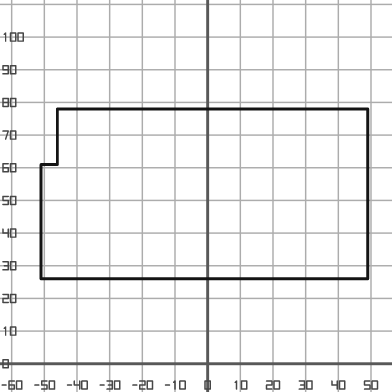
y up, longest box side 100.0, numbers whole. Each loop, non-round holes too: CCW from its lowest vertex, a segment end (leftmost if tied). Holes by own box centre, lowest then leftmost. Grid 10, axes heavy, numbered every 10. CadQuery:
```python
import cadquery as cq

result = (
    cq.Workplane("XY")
    .moveTo(-51.0, 26.0)
    .lineTo(49.0, 26.0)
    .lineTo(49.0, 78.0)
    .lineTo(-46.0, 78.0)
    .lineTo(-46.0, 61.0)
    .lineTo(-51.0, 61.0)
    .close()
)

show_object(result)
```